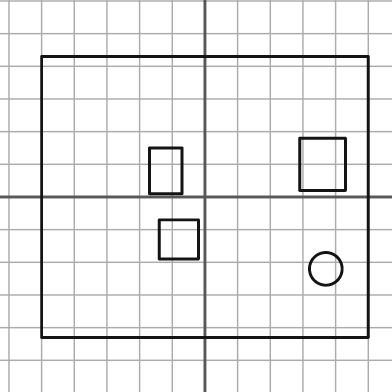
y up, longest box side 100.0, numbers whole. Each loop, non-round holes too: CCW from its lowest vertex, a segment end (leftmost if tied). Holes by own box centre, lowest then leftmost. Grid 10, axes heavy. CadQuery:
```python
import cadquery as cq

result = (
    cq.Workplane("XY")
    .moveTo(-50.0, -43.0)
    .lineTo(50.0, -43.0)
    .lineTo(50.0, 43.0)
    .lineTo(-50.0, 43.0)
    .close()
    .moveTo(37.0, -22.0)
    .circle(5.0)
    .moveTo(-14.0, -19.0)
    .lineTo(-2.0, -19.0)
    .lineTo(-2.0, -7.0)
    .lineTo(-14.0, -7.0)
    .close()
    .moveTo(-17.0, 1.0)
    .lineTo(-7.0, 1.0)
    .lineTo(-7.0, 15.0)
    .lineTo(-17.0, 15.0)
    .close()
    .moveTo(29.0, 2.0)
    .lineTo(43.0, 2.0)
    .lineTo(43.0, 18.0)
    .lineTo(29.0, 18.0)
    .close()
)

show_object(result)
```